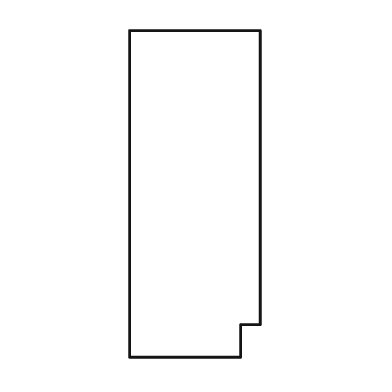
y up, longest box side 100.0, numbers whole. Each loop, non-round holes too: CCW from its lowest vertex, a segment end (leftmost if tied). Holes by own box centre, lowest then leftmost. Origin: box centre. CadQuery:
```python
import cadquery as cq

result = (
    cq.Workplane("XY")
    .moveTo(-20.0, -50.0)
    .lineTo(14.0, -50.0)
    .lineTo(14.0, -40.0)
    .lineTo(20.0, -40.0)
    .lineTo(20.0, 50.0)
    .lineTo(-20.0, 50.0)
    .close()
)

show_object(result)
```